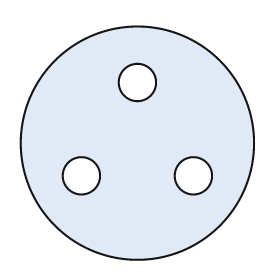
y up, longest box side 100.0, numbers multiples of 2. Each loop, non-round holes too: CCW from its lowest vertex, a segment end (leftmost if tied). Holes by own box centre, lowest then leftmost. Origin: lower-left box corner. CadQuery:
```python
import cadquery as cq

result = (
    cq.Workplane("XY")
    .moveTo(50.0, 50.0)
    .circle(50.0)
    .moveTo(26.0, 36.0)
    .circle(8.0)
    .moveTo(74.0, 36.0)
    .circle(8.0)
    .moveTo(50.0, 76.0)
    .circle(8.0)
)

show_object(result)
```